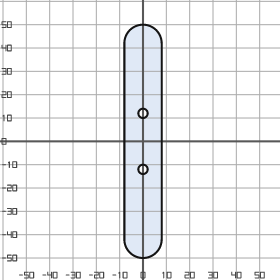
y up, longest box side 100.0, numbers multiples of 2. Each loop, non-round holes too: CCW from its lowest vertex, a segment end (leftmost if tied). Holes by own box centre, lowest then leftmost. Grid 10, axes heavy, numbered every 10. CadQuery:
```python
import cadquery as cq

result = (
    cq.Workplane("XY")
    .moveTo(-8.0, -42.0)
    .threePointArc((0.0, -50.0), (8.0, -42.0))
    .lineTo(8.0, 42.0)
    .threePointArc((0.0, 50.0), (-8.0, 42.0))
    .close()
    .moveTo(0.0, -12.0)
    .circle(2.0)
    .moveTo(0.0, 12.0)
    .circle(2.0)
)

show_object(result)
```